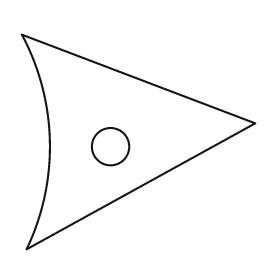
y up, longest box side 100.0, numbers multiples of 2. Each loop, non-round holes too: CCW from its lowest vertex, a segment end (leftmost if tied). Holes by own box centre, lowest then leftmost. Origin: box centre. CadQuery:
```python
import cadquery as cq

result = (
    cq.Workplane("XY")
    .moveTo(-48.0, -46.0)
    .lineTo(50.0, 8.0)
    .lineTo(-50.0, 46.0)
    .threePointArc((-38.0, 0.0), (-48.0, -46.0))
    .close()
    .moveTo(-12.0, -2.0)
    .circle(8.0)
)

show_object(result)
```